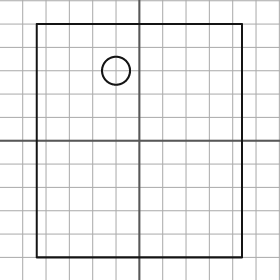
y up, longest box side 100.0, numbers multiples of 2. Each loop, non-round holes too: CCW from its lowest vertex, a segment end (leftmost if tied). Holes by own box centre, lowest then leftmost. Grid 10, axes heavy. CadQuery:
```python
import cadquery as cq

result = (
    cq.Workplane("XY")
    .moveTo(-44.0, -50.0)
    .lineTo(44.0, -50.0)
    .lineTo(44.0, 50.0)
    .lineTo(-44.0, 50.0)
    .close()
    .moveTo(-10.0, 30.0)
    .circle(6.0)
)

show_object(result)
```